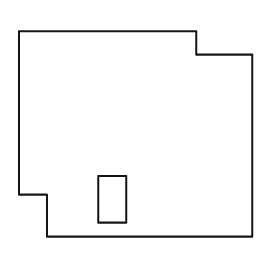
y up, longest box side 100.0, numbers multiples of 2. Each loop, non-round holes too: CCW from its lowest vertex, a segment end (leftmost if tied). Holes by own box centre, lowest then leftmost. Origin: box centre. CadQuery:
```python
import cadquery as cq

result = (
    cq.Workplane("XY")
    .moveTo(-38.0, -44.0)
    .lineTo(50.0, -44.0)
    .lineTo(50.0, 34.0)
    .lineTo(26.0, 34.0)
    .lineTo(26.0, 44.0)
    .lineTo(-50.0, 44.0)
    .lineTo(-50.0, -26.0)
    .lineTo(-38.0, -26.0)
    .close()
    .moveTo(-16.0, -38.0)
    .lineTo(-4.0, -38.0)
    .lineTo(-4.0, -18.0)
    .lineTo(-16.0, -18.0)
    .close()
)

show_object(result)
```